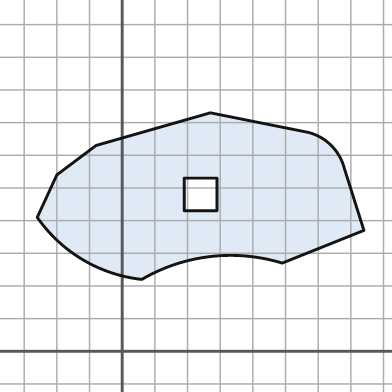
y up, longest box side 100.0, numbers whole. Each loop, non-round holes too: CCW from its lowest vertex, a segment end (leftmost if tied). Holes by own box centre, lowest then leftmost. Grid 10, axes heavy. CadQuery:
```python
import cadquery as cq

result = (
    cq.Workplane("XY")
    .moveTo(6.0, 22.0)
    .threePointArc((27.0, 29.0), (49.0, 27.0))
    .lineTo(74.0, 37.0)
    .lineTo(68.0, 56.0)
    .threePointArc((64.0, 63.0), (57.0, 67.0))
    .lineTo(27.0, 73.0)
    .lineTo(-8.0, 63.0)
    .lineTo(-20.0, 54.0)
    .lineTo(-26.0, 41.0)
    .threePointArc((-12.0, 28.0), (6.0, 22.0))
    .close()
    .moveTo(19.0, 43.0)
    .lineTo(29.0, 43.0)
    .lineTo(29.0, 53.0)
    .lineTo(19.0, 53.0)
    .close()
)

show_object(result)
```